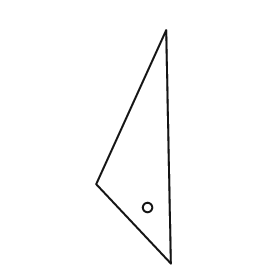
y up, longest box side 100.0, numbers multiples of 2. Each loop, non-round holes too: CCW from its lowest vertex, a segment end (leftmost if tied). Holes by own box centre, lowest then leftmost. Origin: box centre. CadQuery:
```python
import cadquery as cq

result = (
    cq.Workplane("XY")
    .moveTo(16.0, -50.0)
    .lineTo(14.0, 50.0)
    .lineTo(-16.0, -16.0)
    .close()
    .moveTo(6.0, -26.0)
    .circle(2.0)
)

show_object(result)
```